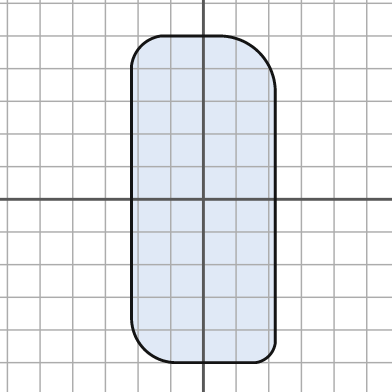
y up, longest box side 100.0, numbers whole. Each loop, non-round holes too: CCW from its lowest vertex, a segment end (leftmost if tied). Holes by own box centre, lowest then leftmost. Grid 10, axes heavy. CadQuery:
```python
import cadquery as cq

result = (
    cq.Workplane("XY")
    .moveTo(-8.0, -50.0)
    .lineTo(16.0, -50.0)
    .threePointArc((20.0, -48.0), (22.0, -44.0))
    .lineTo(22.0, 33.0)
    .threePointArc((17.0, 45.0), (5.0, 50.0))
    .lineTo(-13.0, 50.0)
    .threePointArc((-19.0, 47.0), (-22.0, 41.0))
    .lineTo(-22.0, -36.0)
    .threePointArc((-18.0, -46.0), (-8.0, -50.0))
    .close()
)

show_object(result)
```